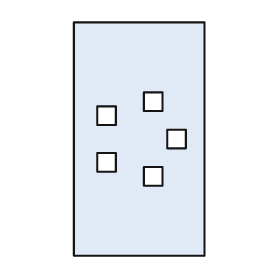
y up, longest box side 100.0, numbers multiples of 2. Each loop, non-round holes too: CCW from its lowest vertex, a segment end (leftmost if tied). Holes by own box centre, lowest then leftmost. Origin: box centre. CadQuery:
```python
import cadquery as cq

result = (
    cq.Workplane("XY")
    .moveTo(-28.0, -50.0)
    .lineTo(28.0, -50.0)
    .lineTo(28.0, 50.0)
    .lineTo(-28.0, 50.0)
    .close()
    .moveTo(2.0, -20.0)
    .lineTo(10.0, -20.0)
    .lineTo(10.0, -12.0)
    .lineTo(2.0, -12.0)
    .close()
    .moveTo(-18.0, -14.0)
    .lineTo(-10.0, -14.0)
    .lineTo(-10.0, -6.0)
    .lineTo(-18.0, -6.0)
    .close()
    .moveTo(12.0, -4.0)
    .lineTo(20.0, -4.0)
    .lineTo(20.0, 4.0)
    .lineTo(12.0, 4.0)
    .close()
    .moveTo(-18.0, 6.0)
    .lineTo(-10.0, 6.0)
    .lineTo(-10.0, 14.0)
    .lineTo(-18.0, 14.0)
    .close()
    .moveTo(2.0, 12.0)
    .lineTo(10.0, 12.0)
    .lineTo(10.0, 20.0)
    .lineTo(2.0, 20.0)
    .close()
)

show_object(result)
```